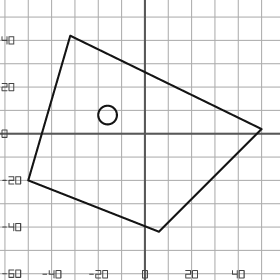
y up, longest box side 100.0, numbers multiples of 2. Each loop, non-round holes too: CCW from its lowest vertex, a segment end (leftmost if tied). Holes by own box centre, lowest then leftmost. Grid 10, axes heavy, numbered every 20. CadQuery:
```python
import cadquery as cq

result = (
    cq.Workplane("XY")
    .moveTo(6.0, -42.0)
    .lineTo(50.0, 2.0)
    .lineTo(-32.0, 42.0)
    .lineTo(-50.0, -20.0)
    .close()
    .moveTo(-16.0, 8.0)
    .circle(4.0)
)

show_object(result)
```